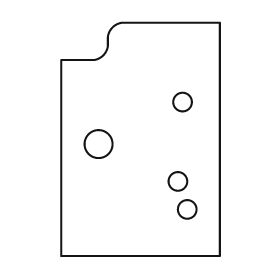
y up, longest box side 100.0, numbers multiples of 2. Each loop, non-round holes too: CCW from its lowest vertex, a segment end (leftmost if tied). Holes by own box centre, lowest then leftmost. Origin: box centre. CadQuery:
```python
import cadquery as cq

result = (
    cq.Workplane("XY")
    .moveTo(-34.0, -50.0)
    .lineTo(34.0, -50.0)
    .lineTo(34.0, 50.0)
    .lineTo(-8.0, 50.0)
    .threePointArc((-12.0, 48.0), (-14.0, 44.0))
    .lineTo(-14.0, 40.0)
    .threePointArc((-16.0, 36.0), (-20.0, 34.0))
    .lineTo(-34.0, 34.0)
    .close()
    .moveTo(20.0, -30.0)
    .circle(4.0)
    .moveTo(16.0, -18.0)
    .circle(4.0)
    .moveTo(-18.0, -2.0)
    .circle(6.0)
    .moveTo(18.0, 16.0)
    .circle(4.0)
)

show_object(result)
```